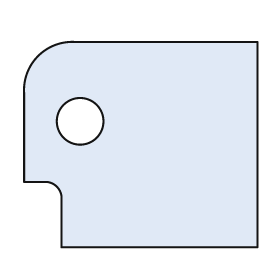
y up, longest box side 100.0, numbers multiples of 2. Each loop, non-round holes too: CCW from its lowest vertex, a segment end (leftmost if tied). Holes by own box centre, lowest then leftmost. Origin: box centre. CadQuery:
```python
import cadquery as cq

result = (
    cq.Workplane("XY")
    .moveTo(-34.0, -44.0)
    .lineTo(50.0, -44.0)
    .lineTo(50.0, 44.0)
    .lineTo(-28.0, 44.0)
    .threePointArc((-44.0, 38.0), (-50.0, 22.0))
    .lineTo(-50.0, -16.0)
    .lineTo(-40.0, -16.0)
    .threePointArc((-36.0, -18.0), (-34.0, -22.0))
    .close()
    .moveTo(-26.0, 10.0)
    .circle(10.0)
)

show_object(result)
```